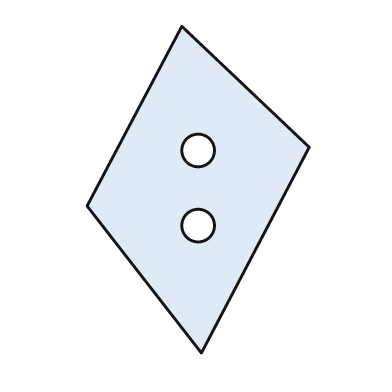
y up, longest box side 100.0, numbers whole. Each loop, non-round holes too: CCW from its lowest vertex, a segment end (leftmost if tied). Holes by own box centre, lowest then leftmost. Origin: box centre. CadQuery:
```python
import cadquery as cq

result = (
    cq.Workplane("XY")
    .moveTo(1.0, -50.0)
    .lineTo(34.0, 13.0)
    .lineTo(-5.0, 50.0)
    .lineTo(-34.0, -5.0)
    .close()
    .moveTo(0.0, -11.0)
    .circle(5.0)
    .moveTo(0.0, 12.0)
    .circle(5.0)
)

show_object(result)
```